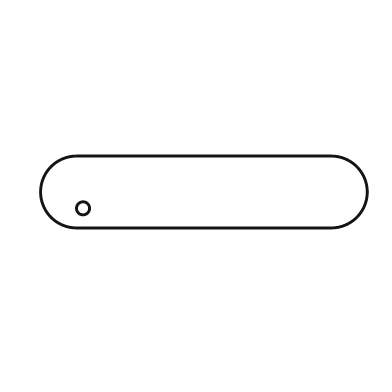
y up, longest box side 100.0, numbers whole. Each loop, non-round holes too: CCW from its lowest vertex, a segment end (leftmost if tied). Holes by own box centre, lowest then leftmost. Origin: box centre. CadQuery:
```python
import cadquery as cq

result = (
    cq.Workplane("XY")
    .moveTo(-39.0, -11.0)
    .lineTo(39.0, -11.0)
    .threePointArc((50.0, 0.0), (39.0, 11.0))
    .lineTo(-39.0, 11.0)
    .threePointArc((-50.0, 0.0), (-39.0, -11.0))
    .close()
    .moveTo(-37.0, -5.0)
    .circle(2.0)
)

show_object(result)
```